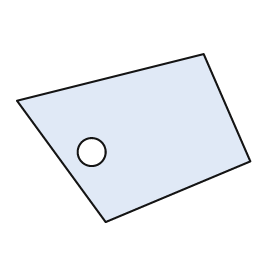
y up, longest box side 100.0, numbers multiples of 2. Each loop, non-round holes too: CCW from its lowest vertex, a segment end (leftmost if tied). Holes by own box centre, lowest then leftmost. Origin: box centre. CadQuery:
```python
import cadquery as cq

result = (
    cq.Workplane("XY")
    .moveTo(-12.0, -36.0)
    .lineTo(50.0, -10.0)
    .lineTo(30.0, 36.0)
    .lineTo(-50.0, 16.0)
    .close()
    .moveTo(-18.0, -6.0)
    .circle(6.0)
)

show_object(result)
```